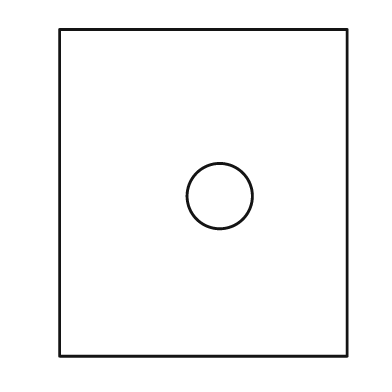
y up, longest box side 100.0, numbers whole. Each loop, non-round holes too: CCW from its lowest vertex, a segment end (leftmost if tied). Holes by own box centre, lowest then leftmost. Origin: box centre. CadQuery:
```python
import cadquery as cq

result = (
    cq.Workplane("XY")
    .moveTo(-44.0, -50.0)
    .lineTo(44.0, -50.0)
    .lineTo(44.0, 50.0)
    .lineTo(-44.0, 50.0)
    .close()
    .moveTo(5.0, -1.0)
    .circle(10.0)
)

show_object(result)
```